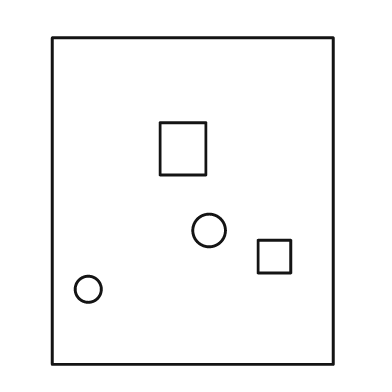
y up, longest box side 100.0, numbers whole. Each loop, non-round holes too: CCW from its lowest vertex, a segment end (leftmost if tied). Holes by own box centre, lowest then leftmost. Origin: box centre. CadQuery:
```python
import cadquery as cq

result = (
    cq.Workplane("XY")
    .moveTo(-43.0, -50.0)
    .lineTo(43.0, -50.0)
    .lineTo(43.0, 50.0)
    .lineTo(-43.0, 50.0)
    .close()
    .moveTo(-32.0, -27.0)
    .circle(4.0)
    .moveTo(20.0, -22.0)
    .lineTo(30.0, -22.0)
    .lineTo(30.0, -12.0)
    .lineTo(20.0, -12.0)
    .close()
    .moveTo(5.0, -9.0)
    .circle(5.0)
    .moveTo(-10.0, 8.0)
    .lineTo(4.0, 8.0)
    .lineTo(4.0, 24.0)
    .lineTo(-10.0, 24.0)
    .close()
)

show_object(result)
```